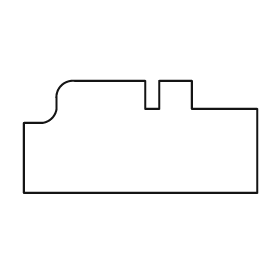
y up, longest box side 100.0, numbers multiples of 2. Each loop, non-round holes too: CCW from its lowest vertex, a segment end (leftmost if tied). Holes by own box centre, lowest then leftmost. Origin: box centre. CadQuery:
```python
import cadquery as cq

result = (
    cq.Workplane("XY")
    .moveTo(-50.0, -24.0)
    .lineTo(50.0, -24.0)
    .lineTo(50.0, 12.0)
    .lineTo(22.0, 12.0)
    .lineTo(22.0, 24.0)
    .lineTo(8.0, 24.0)
    .lineTo(8.0, 12.0)
    .lineTo(2.0, 12.0)
    .lineTo(2.0, 24.0)
    .lineTo(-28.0, 24.0)
    .threePointArc((-34.0, 22.0), (-36.0, 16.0))
    .lineTo(-36.0, 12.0)
    .threePointArc((-38.0, 8.0), (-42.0, 6.0))
    .lineTo(-50.0, 6.0)
    .close()
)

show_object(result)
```